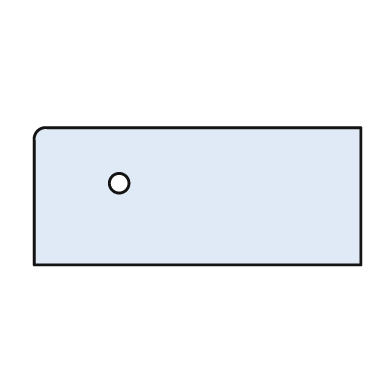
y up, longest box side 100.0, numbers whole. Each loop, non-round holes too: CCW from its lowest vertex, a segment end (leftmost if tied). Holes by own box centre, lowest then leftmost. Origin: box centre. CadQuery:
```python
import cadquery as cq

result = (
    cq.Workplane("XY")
    .moveTo(-50.0, -21.0)
    .lineTo(50.0, -21.0)
    .lineTo(50.0, 21.0)
    .lineTo(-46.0, 21.0)
    .threePointArc((-49.0, 20.0), (-50.0, 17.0))
    .close()
    .moveTo(-24.0, 4.0)
    .circle(3.0)
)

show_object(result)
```